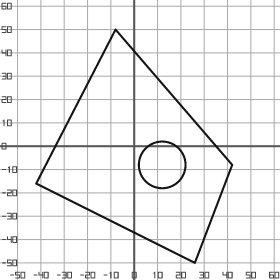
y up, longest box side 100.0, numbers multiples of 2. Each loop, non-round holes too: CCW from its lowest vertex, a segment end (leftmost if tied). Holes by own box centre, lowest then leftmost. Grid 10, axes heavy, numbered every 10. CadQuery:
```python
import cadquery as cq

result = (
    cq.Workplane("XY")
    .moveTo(26.0, -50.0)
    .lineTo(42.0, -8.0)
    .lineTo(-8.0, 50.0)
    .lineTo(-42.0, -16.0)
    .close()
    .moveTo(12.0, -8.0)
    .circle(10.0)
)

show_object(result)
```